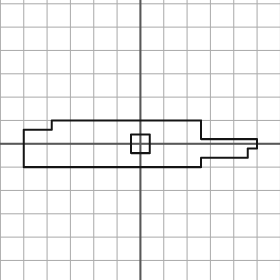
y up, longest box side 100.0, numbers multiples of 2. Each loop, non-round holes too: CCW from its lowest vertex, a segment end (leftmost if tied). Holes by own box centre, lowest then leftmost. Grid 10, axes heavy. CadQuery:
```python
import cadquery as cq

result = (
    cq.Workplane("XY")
    .moveTo(-50.0, -10.0)
    .lineTo(26.0, -10.0)
    .lineTo(26.0, -6.0)
    .lineTo(46.0, -6.0)
    .lineTo(46.0, -2.0)
    .lineTo(50.0, -2.0)
    .lineTo(50.0, 2.0)
    .lineTo(26.0, 2.0)
    .lineTo(26.0, 10.0)
    .lineTo(-38.0, 10.0)
    .lineTo(-38.0, 6.0)
    .lineTo(-50.0, 6.0)
    .close()
    .moveTo(-4.0, -4.0)
    .lineTo(4.0, -4.0)
    .lineTo(4.0, 4.0)
    .lineTo(-4.0, 4.0)
    .close()
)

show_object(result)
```